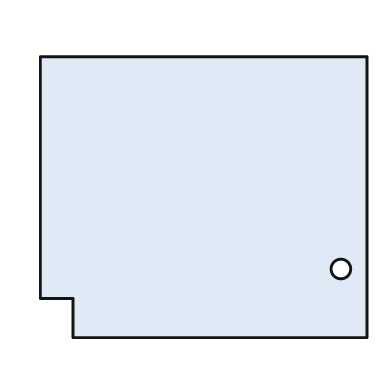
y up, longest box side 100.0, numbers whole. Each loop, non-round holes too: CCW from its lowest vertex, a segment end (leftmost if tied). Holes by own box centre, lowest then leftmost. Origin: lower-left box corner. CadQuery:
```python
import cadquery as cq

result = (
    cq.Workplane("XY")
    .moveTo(10.0, 0.0)
    .lineTo(100.0, 0.0)
    .lineTo(100.0, 86.0)
    .lineTo(0.0, 86.0)
    .lineTo(0.0, 12.0)
    .lineTo(10.0, 12.0)
    .close()
    .moveTo(92.0, 21.0)
    .circle(3.0)
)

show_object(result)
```